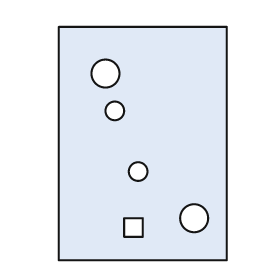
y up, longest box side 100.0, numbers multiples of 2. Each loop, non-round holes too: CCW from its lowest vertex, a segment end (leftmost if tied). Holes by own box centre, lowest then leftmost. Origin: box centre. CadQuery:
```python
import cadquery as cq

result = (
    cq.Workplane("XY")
    .moveTo(-36.0, -50.0)
    .lineTo(36.0, -50.0)
    .lineTo(36.0, 50.0)
    .lineTo(-36.0, 50.0)
    .close()
    .moveTo(-8.0, -40.0)
    .lineTo(0.0, -40.0)
    .lineTo(0.0, -32.0)
    .lineTo(-8.0, -32.0)
    .close()
    .moveTo(22.0, -32.0)
    .circle(6.0)
    .moveTo(-2.0, -12.0)
    .circle(4.0)
    .moveTo(-12.0, 14.0)
    .circle(4.0)
    .moveTo(-16.0, 30.0)
    .circle(6.0)
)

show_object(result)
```